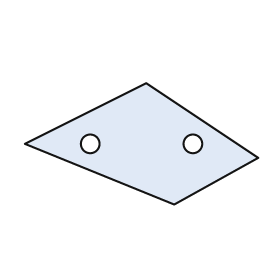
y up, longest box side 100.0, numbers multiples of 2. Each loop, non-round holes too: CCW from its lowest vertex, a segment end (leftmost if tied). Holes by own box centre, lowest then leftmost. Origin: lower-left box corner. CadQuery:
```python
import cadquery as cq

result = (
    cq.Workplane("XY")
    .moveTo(64.0, 0.0)
    .lineTo(100.0, 20.0)
    .lineTo(52.0, 52.0)
    .lineTo(0.0, 26.0)
    .close()
    .moveTo(28.0, 26.0)
    .circle(4.0)
    .moveTo(72.0, 26.0)
    .circle(4.0)
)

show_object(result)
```